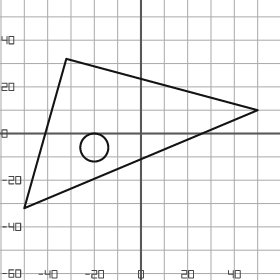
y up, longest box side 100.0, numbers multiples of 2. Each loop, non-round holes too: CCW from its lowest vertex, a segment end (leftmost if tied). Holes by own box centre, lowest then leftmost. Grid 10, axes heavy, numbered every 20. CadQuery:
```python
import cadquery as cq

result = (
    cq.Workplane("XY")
    .moveTo(-50.0, -32.0)
    .lineTo(50.0, 10.0)
    .lineTo(-32.0, 32.0)
    .close()
    .moveTo(-20.0, -6.0)
    .circle(6.0)
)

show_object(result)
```